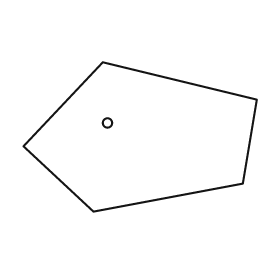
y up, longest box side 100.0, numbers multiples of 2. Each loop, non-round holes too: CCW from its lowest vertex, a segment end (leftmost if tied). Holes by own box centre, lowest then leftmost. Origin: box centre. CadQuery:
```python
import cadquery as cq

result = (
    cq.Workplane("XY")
    .moveTo(-20.0, -32.0)
    .lineTo(44.0, -20.0)
    .lineTo(50.0, 16.0)
    .lineTo(-16.0, 32.0)
    .lineTo(-50.0, -4.0)
    .close()
    .moveTo(-14.0, 6.0)
    .circle(2.0)
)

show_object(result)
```